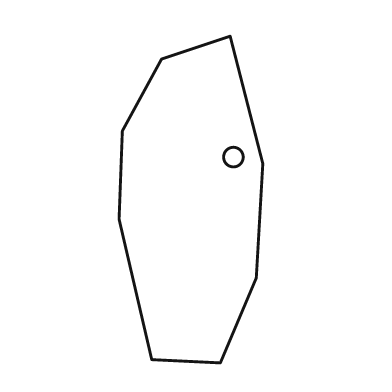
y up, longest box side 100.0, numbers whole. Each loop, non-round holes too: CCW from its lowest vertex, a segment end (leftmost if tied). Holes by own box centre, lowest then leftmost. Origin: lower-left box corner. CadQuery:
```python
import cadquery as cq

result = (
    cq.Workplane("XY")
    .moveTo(31.0, 0.0)
    .lineTo(42.0, 26.0)
    .lineTo(44.0, 61.0)
    .lineTo(34.0, 100.0)
    .lineTo(13.0, 93.0)
    .lineTo(1.0, 71.0)
    .lineTo(0.0, 44.0)
    .lineTo(10.0, 1.0)
    .close()
    .moveTo(35.0, 63.0)
    .circle(3.0)
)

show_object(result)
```